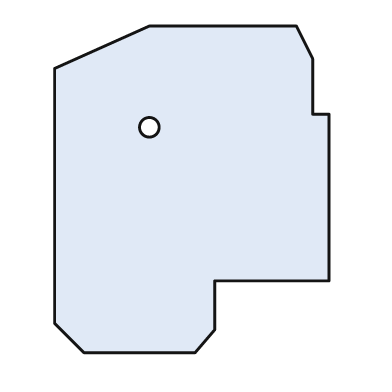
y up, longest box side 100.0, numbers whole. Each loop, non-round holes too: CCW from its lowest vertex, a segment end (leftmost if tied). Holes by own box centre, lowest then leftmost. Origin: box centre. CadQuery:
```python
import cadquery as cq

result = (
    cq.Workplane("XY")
    .moveTo(-33.0, -50.0)
    .lineTo(1.0, -50.0)
    .lineTo(7.0, -43.0)
    .lineTo(7.0, -28.0)
    .lineTo(42.0, -28.0)
    .lineTo(42.0, 23.0)
    .lineTo(37.0, 23.0)
    .lineTo(37.0, 40.0)
    .lineTo(32.0, 50.0)
    .lineTo(-13.0, 50.0)
    .lineTo(-42.0, 37.0)
    .lineTo(-42.0, -41.0)
    .close()
    .moveTo(-13.0, 19.0)
    .circle(3.0)
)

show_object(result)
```